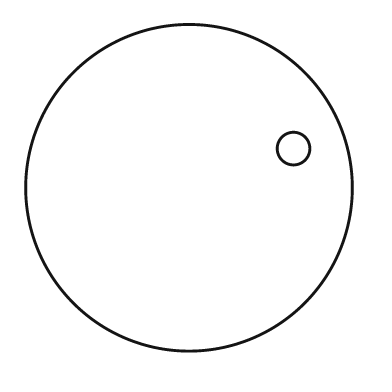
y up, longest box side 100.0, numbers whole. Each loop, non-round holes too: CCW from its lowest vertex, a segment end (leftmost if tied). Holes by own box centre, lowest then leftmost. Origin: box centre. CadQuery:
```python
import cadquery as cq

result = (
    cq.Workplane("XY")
    .moveTo(0.0, 0.0)
    .circle(50.0)
    .moveTo(32.0, 12.0)
    .circle(5.0)
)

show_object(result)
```